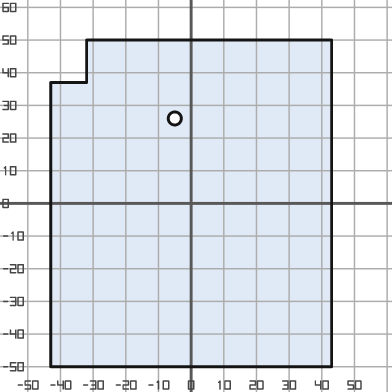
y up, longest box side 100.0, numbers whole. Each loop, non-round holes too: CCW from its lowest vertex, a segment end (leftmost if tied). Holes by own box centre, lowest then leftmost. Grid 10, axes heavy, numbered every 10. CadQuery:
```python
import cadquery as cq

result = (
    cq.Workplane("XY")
    .moveTo(-43.0, -50.0)
    .lineTo(43.0, -50.0)
    .lineTo(43.0, 50.0)
    .lineTo(-32.0, 50.0)
    .lineTo(-32.0, 37.0)
    .lineTo(-43.0, 37.0)
    .close()
    .moveTo(-5.0, 26.0)
    .circle(2.0)
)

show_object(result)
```